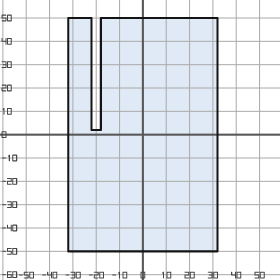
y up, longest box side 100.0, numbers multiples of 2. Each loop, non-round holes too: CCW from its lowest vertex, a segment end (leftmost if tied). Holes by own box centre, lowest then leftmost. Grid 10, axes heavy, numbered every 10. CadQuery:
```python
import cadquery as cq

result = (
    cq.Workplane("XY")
    .moveTo(-32.0, -50.0)
    .lineTo(32.0, -50.0)
    .lineTo(32.0, 50.0)
    .lineTo(-18.0, 50.0)
    .lineTo(-18.0, 2.0)
    .lineTo(-22.0, 2.0)
    .lineTo(-22.0, 50.0)
    .lineTo(-32.0, 50.0)
    .close()
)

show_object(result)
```